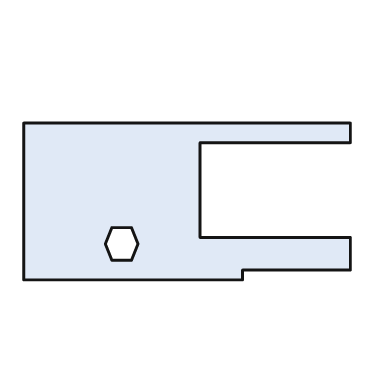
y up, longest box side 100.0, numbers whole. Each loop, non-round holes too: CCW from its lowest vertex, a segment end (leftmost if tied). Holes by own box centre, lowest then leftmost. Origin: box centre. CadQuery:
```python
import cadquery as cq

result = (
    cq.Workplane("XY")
    .moveTo(-50.0, -24.0)
    .lineTo(17.0, -24.0)
    .lineTo(17.0, -21.0)
    .lineTo(50.0, -21.0)
    .lineTo(50.0, -11.0)
    .lineTo(4.0, -11.0)
    .lineTo(4.0, 18.0)
    .lineTo(50.0, 18.0)
    .lineTo(50.0, 24.0)
    .lineTo(-50.0, 24.0)
    .close()
    .moveTo(-23.0, -18.0)
    .lineTo(-17.0, -18.0)
    .lineTo(-15.0, -13.0)
    .lineTo(-17.0, -8.0)
    .lineTo(-23.0, -8.0)
    .lineTo(-25.0, -13.0)
    .close()
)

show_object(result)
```